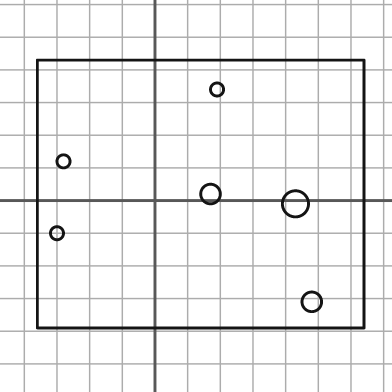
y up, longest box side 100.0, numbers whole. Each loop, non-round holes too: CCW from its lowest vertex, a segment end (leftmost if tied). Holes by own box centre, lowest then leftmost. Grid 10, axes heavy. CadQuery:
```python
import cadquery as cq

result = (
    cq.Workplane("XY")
    .moveTo(-36.0, -39.0)
    .lineTo(64.0, -39.0)
    .lineTo(64.0, 43.0)
    .lineTo(-36.0, 43.0)
    .close()
    .moveTo(48.0, -31.0)
    .circle(3.0)
    .moveTo(-30.0, -10.0)
    .circle(2.0)
    .moveTo(43.0, -1.0)
    .circle(4.0)
    .moveTo(17.0, 2.0)
    .circle(3.0)
    .moveTo(-28.0, 12.0)
    .circle(2.0)
    .moveTo(19.0, 34.0)
    .circle(2.0)
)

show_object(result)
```